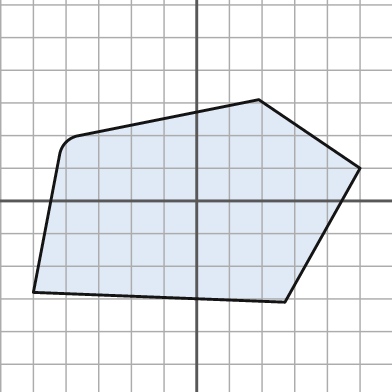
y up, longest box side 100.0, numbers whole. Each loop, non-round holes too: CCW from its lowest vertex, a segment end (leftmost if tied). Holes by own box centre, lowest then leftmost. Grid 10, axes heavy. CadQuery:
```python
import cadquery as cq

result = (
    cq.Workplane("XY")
    .moveTo(27.0, -31.0)
    .lineTo(50.0, 10.0)
    .lineTo(19.0, 31.0)
    .lineTo(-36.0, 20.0)
    .threePointArc((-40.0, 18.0), (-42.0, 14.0))
    .lineTo(-50.0, -28.0)
    .close()
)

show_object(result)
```